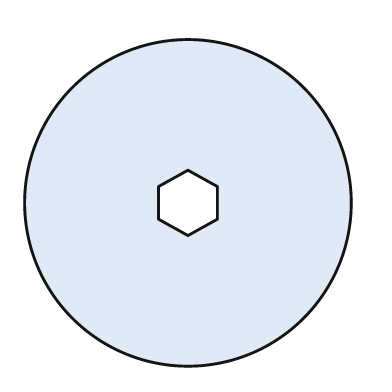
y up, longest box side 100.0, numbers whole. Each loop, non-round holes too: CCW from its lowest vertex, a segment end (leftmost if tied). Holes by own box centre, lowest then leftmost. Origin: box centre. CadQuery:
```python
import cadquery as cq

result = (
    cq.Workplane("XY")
    .moveTo(0.0, 0.0)
    .circle(50.0)
    .moveTo(0.0, -10.0)
    .lineTo(9.0, -5.0)
    .lineTo(9.0, 5.0)
    .lineTo(0.0, 10.0)
    .lineTo(-9.0, 5.0)
    .lineTo(-9.0, -5.0)
    .close()
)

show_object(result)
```